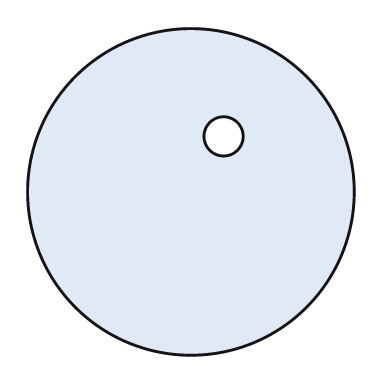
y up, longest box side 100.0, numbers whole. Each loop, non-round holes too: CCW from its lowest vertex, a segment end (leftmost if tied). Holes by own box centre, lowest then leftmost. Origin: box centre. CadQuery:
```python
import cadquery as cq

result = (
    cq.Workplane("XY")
    .moveTo(0.0, 0.0)
    .circle(50.0)
    .moveTo(10.0, 17.0)
    .circle(6.0)
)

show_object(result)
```